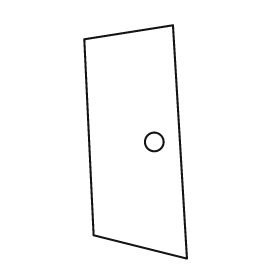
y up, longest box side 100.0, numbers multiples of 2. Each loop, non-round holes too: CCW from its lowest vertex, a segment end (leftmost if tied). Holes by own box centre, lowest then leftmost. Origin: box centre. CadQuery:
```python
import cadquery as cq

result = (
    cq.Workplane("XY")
    .moveTo(22.0, -50.0)
    .lineTo(16.0, 50.0)
    .lineTo(-22.0, 44.0)
    .lineTo(-18.0, -40.0)
    .close()
    .moveTo(8.0, 0.0)
    .circle(4.0)
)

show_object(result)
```